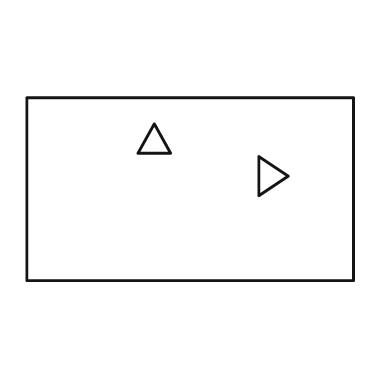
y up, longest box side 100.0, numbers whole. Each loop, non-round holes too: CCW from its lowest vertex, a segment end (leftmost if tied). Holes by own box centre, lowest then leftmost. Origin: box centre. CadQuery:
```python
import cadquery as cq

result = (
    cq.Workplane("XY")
    .moveTo(-50.0, -28.0)
    .lineTo(50.0, -28.0)
    .lineTo(50.0, 28.0)
    .lineTo(-50.0, 28.0)
    .close()
    .moveTo(21.0, -2.0)
    .lineTo(30.0, 4.0)
    .lineTo(21.0, 10.0)
    .close()
    .moveTo(-16.0, 11.0)
    .lineTo(-6.0, 11.0)
    .lineTo(-11.0, 20.0)
    .close()
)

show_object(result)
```